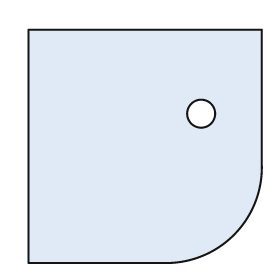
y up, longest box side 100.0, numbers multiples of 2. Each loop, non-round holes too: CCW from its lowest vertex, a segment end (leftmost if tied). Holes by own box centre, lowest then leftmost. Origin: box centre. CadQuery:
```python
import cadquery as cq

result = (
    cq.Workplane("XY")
    .moveTo(-50.0, -50.0)
    .lineTo(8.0, -50.0)
    .threePointArc((38.0, -38.0), (50.0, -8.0))
    .lineTo(50.0, 50.0)
    .lineTo(-50.0, 50.0)
    .close()
    .moveTo(24.0, 14.0)
    .circle(6.0)
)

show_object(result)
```